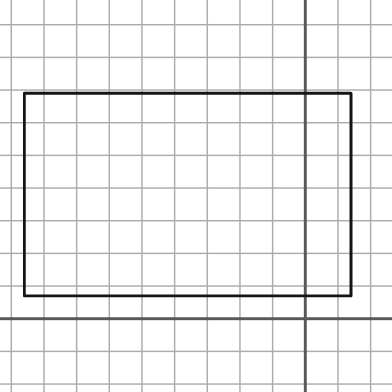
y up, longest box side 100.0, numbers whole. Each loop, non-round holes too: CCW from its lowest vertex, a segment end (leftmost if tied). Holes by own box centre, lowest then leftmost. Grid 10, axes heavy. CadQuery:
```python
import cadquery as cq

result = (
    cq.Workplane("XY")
    .moveTo(-86.0, 7.0)
    .lineTo(14.0, 7.0)
    .lineTo(14.0, 69.0)
    .lineTo(-86.0, 69.0)
    .close()
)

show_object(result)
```